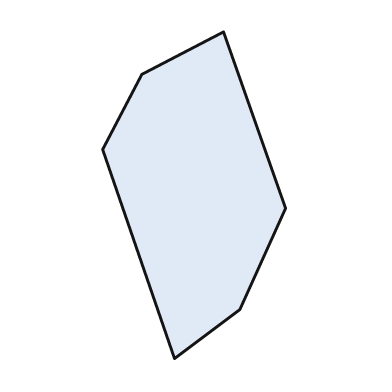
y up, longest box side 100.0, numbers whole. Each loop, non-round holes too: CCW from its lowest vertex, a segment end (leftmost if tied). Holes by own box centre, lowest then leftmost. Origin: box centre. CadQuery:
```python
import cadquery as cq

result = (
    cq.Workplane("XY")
    .moveTo(-6.0, -50.0)
    .lineTo(14.0, -35.0)
    .lineTo(28.0, -4.0)
    .lineTo(9.0, 50.0)
    .lineTo(-16.0, 37.0)
    .lineTo(-28.0, 14.0)
    .close()
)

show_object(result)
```